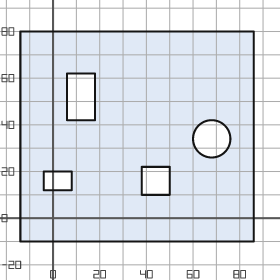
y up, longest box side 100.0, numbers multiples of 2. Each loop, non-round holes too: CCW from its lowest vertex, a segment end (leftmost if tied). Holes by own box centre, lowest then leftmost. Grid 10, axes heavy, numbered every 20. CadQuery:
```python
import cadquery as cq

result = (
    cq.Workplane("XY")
    .moveTo(-14.0, -10.0)
    .lineTo(86.0, -10.0)
    .lineTo(86.0, 80.0)
    .lineTo(-14.0, 80.0)
    .close()
    .moveTo(-4.0, 12.0)
    .lineTo(8.0, 12.0)
    .lineTo(8.0, 20.0)
    .lineTo(-4.0, 20.0)
    .close()
    .moveTo(38.0, 10.0)
    .lineTo(50.0, 10.0)
    .lineTo(50.0, 22.0)
    .lineTo(38.0, 22.0)
    .close()
    .moveTo(68.0, 34.0)
    .circle(8.0)
    .moveTo(6.0, 42.0)
    .lineTo(18.0, 42.0)
    .lineTo(18.0, 62.0)
    .lineTo(6.0, 62.0)
    .close()
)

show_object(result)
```